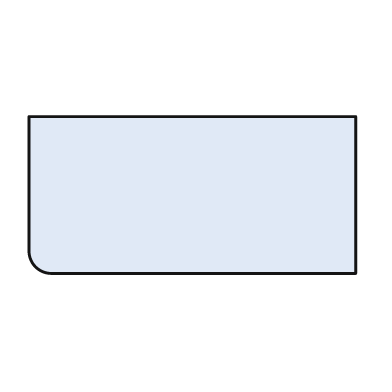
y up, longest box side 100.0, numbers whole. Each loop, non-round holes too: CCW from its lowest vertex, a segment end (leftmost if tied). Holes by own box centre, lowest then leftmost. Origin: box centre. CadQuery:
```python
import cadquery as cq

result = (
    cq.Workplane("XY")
    .moveTo(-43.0, -24.0)
    .lineTo(50.0, -24.0)
    .lineTo(50.0, 24.0)
    .lineTo(-50.0, 24.0)
    .lineTo(-50.0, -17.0)
    .threePointArc((-48.0, -22.0), (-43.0, -24.0))
    .close()
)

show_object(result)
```